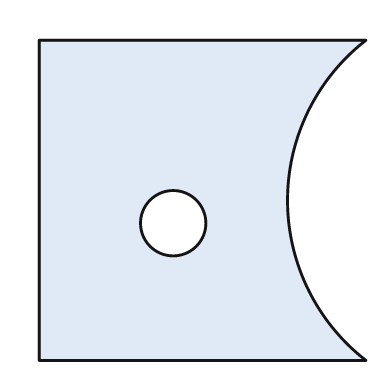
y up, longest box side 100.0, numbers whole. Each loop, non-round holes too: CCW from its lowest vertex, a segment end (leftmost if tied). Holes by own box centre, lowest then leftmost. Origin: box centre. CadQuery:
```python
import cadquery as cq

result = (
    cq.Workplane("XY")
    .moveTo(-50.0, -49.0)
    .lineTo(50.0, -49.0)
    .threePointArc((26.0, 0.0), (50.0, 49.0))
    .lineTo(-50.0, 49.0)
    .close()
    .moveTo(-9.0, -7.0)
    .circle(10.0)
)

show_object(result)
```